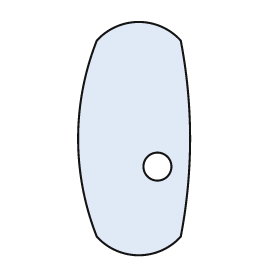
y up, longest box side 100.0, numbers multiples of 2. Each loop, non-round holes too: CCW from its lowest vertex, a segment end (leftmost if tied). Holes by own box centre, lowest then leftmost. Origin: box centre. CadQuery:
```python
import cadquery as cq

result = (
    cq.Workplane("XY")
    .moveTo(-16.0, -42.0)
    .threePointArc((2.0, -50.0), (20.0, -42.0))
    .threePointArc((24.0, 0.0), (20.0, 42.0))
    .threePointArc((2.0, 50.0), (-16.0, 42.0))
    .threePointArc((-24.0, 0.0), (-16.0, -42.0))
    .close()
    .moveTo(10.0, -12.0)
    .circle(6.0)
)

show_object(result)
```